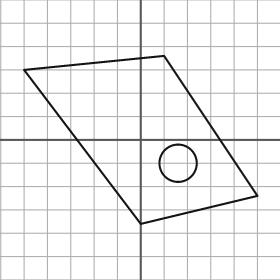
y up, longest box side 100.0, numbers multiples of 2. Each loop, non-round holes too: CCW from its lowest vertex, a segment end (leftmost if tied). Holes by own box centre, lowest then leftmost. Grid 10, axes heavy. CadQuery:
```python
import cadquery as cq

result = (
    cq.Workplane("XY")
    .moveTo(0.0, -36.0)
    .lineTo(50.0, -24.0)
    .lineTo(10.0, 36.0)
    .lineTo(-50.0, 30.0)
    .close()
    .moveTo(16.0, -10.0)
    .circle(8.0)
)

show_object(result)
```